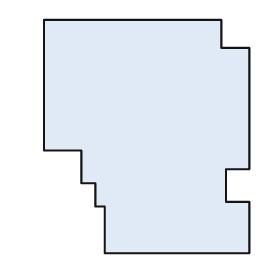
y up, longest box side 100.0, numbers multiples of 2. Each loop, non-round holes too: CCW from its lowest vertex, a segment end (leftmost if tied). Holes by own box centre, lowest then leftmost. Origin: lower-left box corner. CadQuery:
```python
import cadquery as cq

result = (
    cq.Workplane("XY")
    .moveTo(26.0, 0.0)
    .lineTo(88.0, 0.0)
    .lineTo(88.0, 22.0)
    .lineTo(78.0, 22.0)
    .lineTo(78.0, 36.0)
    .lineTo(88.0, 36.0)
    .lineTo(88.0, 88.0)
    .lineTo(76.0, 88.0)
    .lineTo(76.0, 100.0)
    .lineTo(0.0, 100.0)
    .lineTo(0.0, 44.0)
    .lineTo(16.0, 44.0)
    .lineTo(16.0, 30.0)
    .lineTo(22.0, 30.0)
    .lineTo(22.0, 20.0)
    .lineTo(26.0, 20.0)
    .close()
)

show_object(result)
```